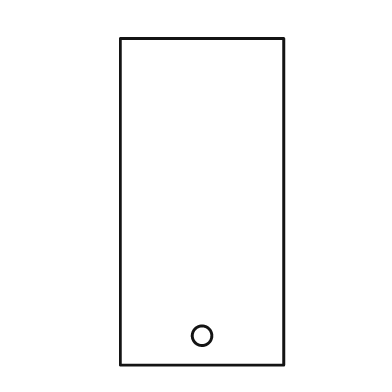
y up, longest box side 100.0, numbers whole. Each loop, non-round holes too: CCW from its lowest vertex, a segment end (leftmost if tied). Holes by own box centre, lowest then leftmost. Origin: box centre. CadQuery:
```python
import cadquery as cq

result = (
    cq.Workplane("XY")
    .moveTo(-25.0, -50.0)
    .lineTo(25.0, -50.0)
    .lineTo(25.0, 50.0)
    .lineTo(-25.0, 50.0)
    .close()
    .moveTo(0.0, -41.0)
    .circle(3.0)
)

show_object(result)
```